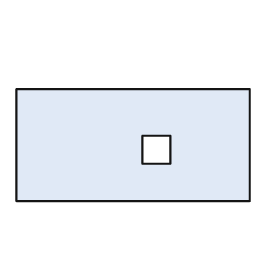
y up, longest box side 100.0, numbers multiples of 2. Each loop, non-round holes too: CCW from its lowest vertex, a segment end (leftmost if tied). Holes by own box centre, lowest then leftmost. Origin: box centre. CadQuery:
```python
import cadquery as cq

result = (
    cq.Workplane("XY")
    .moveTo(-50.0, -24.0)
    .lineTo(50.0, -24.0)
    .lineTo(50.0, 24.0)
    .lineTo(-50.0, 24.0)
    .close()
    .moveTo(4.0, -8.0)
    .lineTo(16.0, -8.0)
    .lineTo(16.0, 4.0)
    .lineTo(4.0, 4.0)
    .close()
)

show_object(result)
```